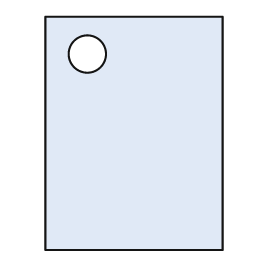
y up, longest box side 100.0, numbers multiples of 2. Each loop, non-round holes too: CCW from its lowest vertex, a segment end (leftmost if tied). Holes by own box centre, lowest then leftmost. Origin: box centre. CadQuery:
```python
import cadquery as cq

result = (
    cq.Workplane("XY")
    .moveTo(-38.0, -50.0)
    .lineTo(38.0, -50.0)
    .lineTo(38.0, 50.0)
    .lineTo(-38.0, 50.0)
    .close()
    .moveTo(-20.0, 34.0)
    .circle(8.0)
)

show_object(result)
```